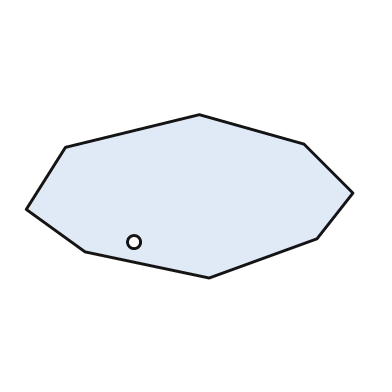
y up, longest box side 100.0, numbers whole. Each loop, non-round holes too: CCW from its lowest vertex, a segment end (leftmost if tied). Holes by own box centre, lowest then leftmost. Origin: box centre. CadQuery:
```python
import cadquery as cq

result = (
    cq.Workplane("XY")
    .moveTo(6.0, -25.0)
    .lineTo(39.0, -13.0)
    .lineTo(50.0, 1.0)
    .lineTo(35.0, 16.0)
    .lineTo(3.0, 25.0)
    .lineTo(-38.0, 15.0)
    .lineTo(-50.0, -4.0)
    .lineTo(-32.0, -17.0)
    .close()
    .moveTo(-17.0, -14.0)
    .circle(2.0)
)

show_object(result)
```